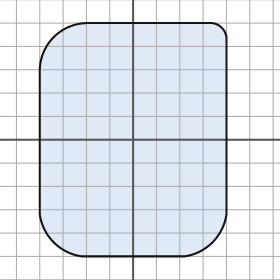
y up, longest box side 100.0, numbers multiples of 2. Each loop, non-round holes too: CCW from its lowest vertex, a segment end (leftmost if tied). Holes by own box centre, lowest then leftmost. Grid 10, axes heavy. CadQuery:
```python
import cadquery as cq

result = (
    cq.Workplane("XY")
    .moveTo(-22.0, -50.0)
    .lineTo(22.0, -50.0)
    .threePointArc((34.0, -44.0), (40.0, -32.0))
    .lineTo(40.0, 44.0)
    .threePointArc((38.0, 48.0), (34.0, 50.0))
    .lineTo(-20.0, 50.0)
    .threePointArc((-34.0, 44.0), (-40.0, 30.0))
    .lineTo(-40.0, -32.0)
    .threePointArc((-34.0, -44.0), (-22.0, -50.0))
    .close()
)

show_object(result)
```